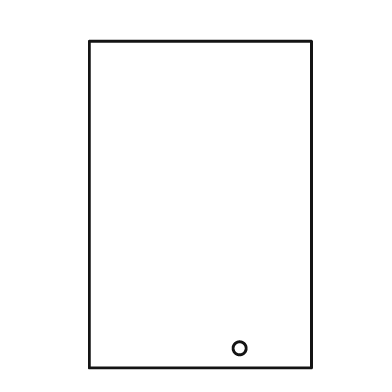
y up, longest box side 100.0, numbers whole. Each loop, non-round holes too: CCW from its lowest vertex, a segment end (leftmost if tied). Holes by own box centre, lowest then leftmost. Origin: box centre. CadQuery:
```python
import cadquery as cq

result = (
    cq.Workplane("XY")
    .moveTo(-34.0, -50.0)
    .lineTo(34.0, -50.0)
    .lineTo(34.0, 50.0)
    .lineTo(-34.0, 50.0)
    .close()
    .moveTo(12.0, -44.0)
    .circle(2.0)
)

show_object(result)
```